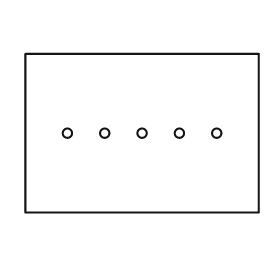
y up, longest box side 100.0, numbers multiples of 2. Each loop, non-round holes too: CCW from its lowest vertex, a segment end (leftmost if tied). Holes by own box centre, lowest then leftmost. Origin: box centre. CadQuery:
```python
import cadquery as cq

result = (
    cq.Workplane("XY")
    .moveTo(-50.0, -34.0)
    .lineTo(50.0, -34.0)
    .lineTo(50.0, 34.0)
    .lineTo(-50.0, 34.0)
    .close()
    .moveTo(-32.0, 0.0)
    .circle(2.0)
    .moveTo(-16.0, 0.0)
    .circle(2.0)
    .moveTo(0.0, 0.0)
    .circle(2.0)
    .moveTo(16.0, 0.0)
    .circle(2.0)
    .moveTo(32.0, 0.0)
    .circle(2.0)
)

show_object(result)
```